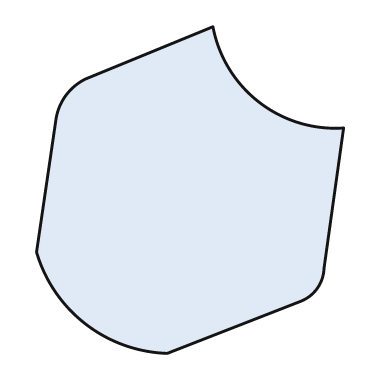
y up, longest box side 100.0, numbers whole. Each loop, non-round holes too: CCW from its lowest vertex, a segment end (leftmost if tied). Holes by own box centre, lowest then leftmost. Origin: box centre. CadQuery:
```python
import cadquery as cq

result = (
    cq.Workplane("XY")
    .moveTo(-7.0, -50.0)
    .lineTo(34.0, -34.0)
    .threePointArc((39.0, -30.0), (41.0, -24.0))
    .lineTo(47.0, 19.0)
    .threePointArc((21.0, 27.0), (7.0, 50.0))
    .lineTo(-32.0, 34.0)
    .threePointArc((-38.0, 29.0), (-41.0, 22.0))
    .lineTo(-47.0, -19.0)
    .threePointArc((-32.0, -41.0), (-7.0, -50.0))
    .close()
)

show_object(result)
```